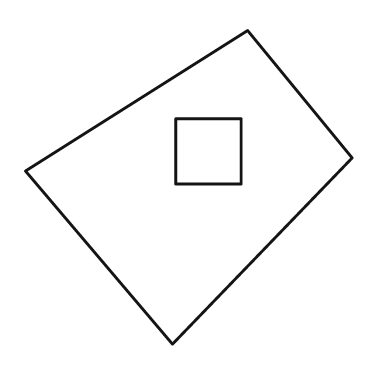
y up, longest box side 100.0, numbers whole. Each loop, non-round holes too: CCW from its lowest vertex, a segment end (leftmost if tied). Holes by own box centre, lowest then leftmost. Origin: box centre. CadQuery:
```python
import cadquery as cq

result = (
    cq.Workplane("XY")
    .moveTo(-5.0, -48.0)
    .lineTo(50.0, 9.0)
    .lineTo(18.0, 48.0)
    .lineTo(-50.0, 5.0)
    .close()
    .moveTo(-4.0, 1.0)
    .lineTo(16.0, 1.0)
    .lineTo(16.0, 21.0)
    .lineTo(-4.0, 21.0)
    .close()
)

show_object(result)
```